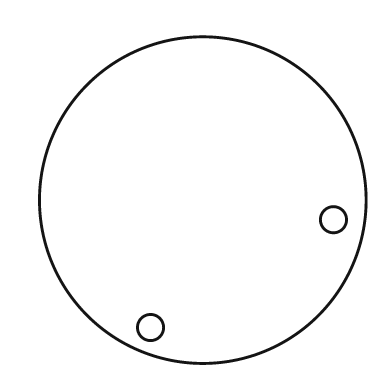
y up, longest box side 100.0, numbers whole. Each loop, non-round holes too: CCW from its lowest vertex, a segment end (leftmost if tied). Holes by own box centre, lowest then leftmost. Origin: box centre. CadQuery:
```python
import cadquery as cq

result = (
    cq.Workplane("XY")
    .moveTo(0.0, 0.0)
    .circle(50.0)
    .moveTo(-16.0, -39.0)
    .circle(4.0)
    .moveTo(40.0, -6.0)
    .circle(4.0)
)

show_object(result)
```